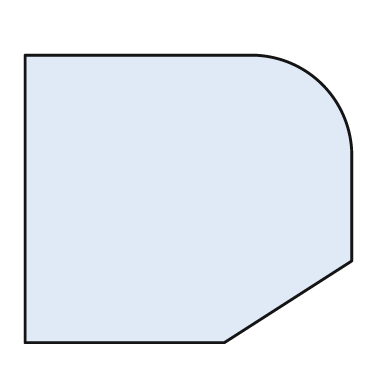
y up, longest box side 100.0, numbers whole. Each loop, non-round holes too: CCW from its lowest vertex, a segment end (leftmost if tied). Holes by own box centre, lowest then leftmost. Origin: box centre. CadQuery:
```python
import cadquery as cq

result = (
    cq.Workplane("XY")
    .moveTo(-50.0, -44.0)
    .lineTo(11.0, -44.0)
    .lineTo(50.0, -19.0)
    .lineTo(50.0, 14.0)
    .threePointArc((41.0, 35.0), (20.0, 44.0))
    .lineTo(-50.0, 44.0)
    .close()
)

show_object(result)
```